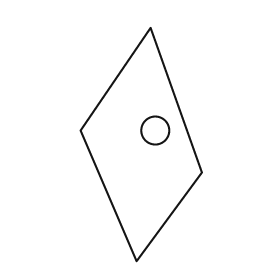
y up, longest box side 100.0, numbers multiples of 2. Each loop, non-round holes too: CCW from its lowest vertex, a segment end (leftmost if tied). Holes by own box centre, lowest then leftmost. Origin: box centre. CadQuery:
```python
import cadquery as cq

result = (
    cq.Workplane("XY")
    .moveTo(-2.0, -50.0)
    .lineTo(26.0, -12.0)
    .lineTo(4.0, 50.0)
    .lineTo(-26.0, 6.0)
    .close()
    .moveTo(6.0, 6.0)
    .circle(6.0)
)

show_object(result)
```